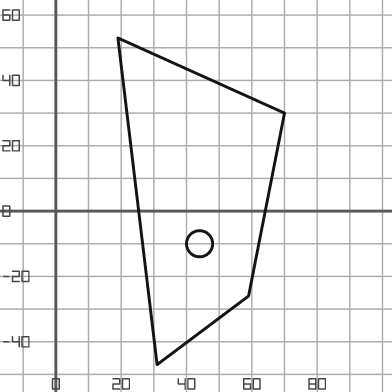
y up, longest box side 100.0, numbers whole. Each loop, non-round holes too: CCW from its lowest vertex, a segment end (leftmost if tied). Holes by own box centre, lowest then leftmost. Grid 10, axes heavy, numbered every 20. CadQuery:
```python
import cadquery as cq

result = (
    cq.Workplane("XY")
    .moveTo(31.0, -47.0)
    .lineTo(59.0, -26.0)
    .lineTo(70.0, 30.0)
    .lineTo(19.0, 53.0)
    .close()
    .moveTo(44.0, -10.0)
    .circle(4.0)
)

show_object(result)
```